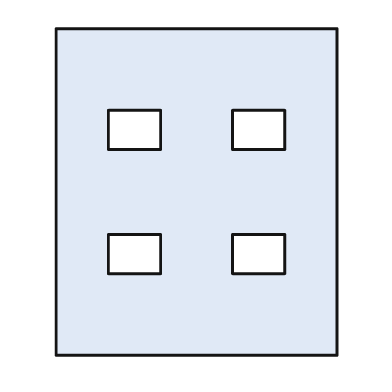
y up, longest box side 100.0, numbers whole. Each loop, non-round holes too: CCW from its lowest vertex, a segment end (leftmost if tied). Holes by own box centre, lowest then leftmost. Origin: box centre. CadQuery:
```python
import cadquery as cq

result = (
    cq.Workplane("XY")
    .moveTo(-43.0, -50.0)
    .lineTo(43.0, -50.0)
    .lineTo(43.0, 50.0)
    .lineTo(-43.0, 50.0)
    .close()
    .moveTo(-27.0, -25.0)
    .lineTo(-11.0, -25.0)
    .lineTo(-11.0, -13.0)
    .lineTo(-27.0, -13.0)
    .close()
    .moveTo(11.0, -25.0)
    .lineTo(27.0, -25.0)
    .lineTo(27.0, -13.0)
    .lineTo(11.0, -13.0)
    .close()
    .moveTo(-27.0, 13.0)
    .lineTo(-11.0, 13.0)
    .lineTo(-11.0, 25.0)
    .lineTo(-27.0, 25.0)
    .close()
    .moveTo(11.0, 13.0)
    .lineTo(27.0, 13.0)
    .lineTo(27.0, 25.0)
    .lineTo(11.0, 25.0)
    .close()
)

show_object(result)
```